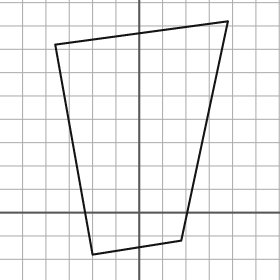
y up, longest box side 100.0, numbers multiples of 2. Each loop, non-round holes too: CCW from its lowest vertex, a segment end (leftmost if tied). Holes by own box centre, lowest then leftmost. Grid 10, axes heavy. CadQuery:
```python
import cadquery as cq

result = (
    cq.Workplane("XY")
    .moveTo(-20.0, -18.0)
    .lineTo(18.0, -12.0)
    .lineTo(38.0, 82.0)
    .lineTo(-36.0, 72.0)
    .close()
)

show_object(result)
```